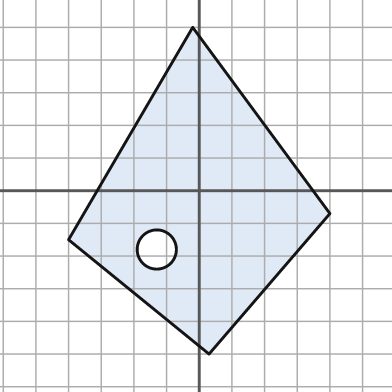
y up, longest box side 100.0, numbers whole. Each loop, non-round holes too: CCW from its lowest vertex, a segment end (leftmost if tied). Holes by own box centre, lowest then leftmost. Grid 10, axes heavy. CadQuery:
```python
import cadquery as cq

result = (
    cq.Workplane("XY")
    .moveTo(3.0, -50.0)
    .lineTo(40.0, -7.0)
    .lineTo(-2.0, 50.0)
    .lineTo(-40.0, -15.0)
    .close()
    .moveTo(-13.0, -18.0)
    .circle(6.0)
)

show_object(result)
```